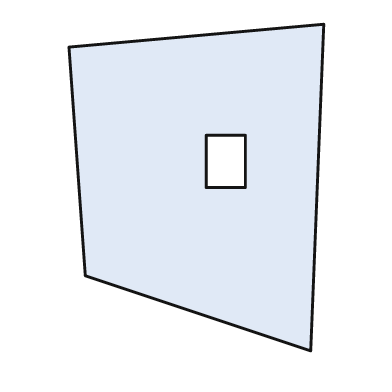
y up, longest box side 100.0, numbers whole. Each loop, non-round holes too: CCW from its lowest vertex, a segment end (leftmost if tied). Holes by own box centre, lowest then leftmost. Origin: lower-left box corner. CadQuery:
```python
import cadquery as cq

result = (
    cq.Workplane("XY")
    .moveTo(74.0, 0.0)
    .lineTo(78.0, 100.0)
    .lineTo(0.0, 93.0)
    .lineTo(5.0, 23.0)
    .close()
    .moveTo(42.0, 50.0)
    .lineTo(54.0, 50.0)
    .lineTo(54.0, 66.0)
    .lineTo(42.0, 66.0)
    .close()
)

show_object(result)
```